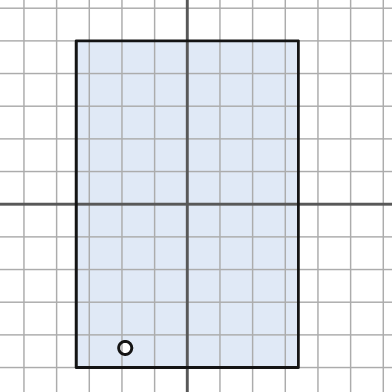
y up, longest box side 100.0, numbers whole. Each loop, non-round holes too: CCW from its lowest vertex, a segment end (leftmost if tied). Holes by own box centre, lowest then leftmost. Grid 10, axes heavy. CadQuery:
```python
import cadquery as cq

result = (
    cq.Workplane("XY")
    .moveTo(-34.0, -50.0)
    .lineTo(34.0, -50.0)
    .lineTo(34.0, 50.0)
    .lineTo(-34.0, 50.0)
    .close()
    .moveTo(-19.0, -44.0)
    .circle(2.0)
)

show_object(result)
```